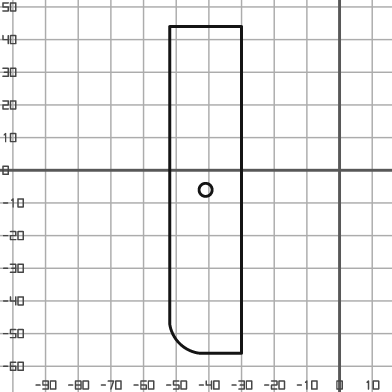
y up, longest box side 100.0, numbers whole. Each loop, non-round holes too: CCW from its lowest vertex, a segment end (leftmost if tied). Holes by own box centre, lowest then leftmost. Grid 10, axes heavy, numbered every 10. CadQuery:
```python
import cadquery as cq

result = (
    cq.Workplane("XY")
    .moveTo(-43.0, -56.0)
    .lineTo(-30.0, -56.0)
    .lineTo(-30.0, 44.0)
    .lineTo(-52.0, 44.0)
    .lineTo(-52.0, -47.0)
    .threePointArc((-49.0, -53.0), (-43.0, -56.0))
    .close()
    .moveTo(-41.0, -6.0)
    .circle(2.0)
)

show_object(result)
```